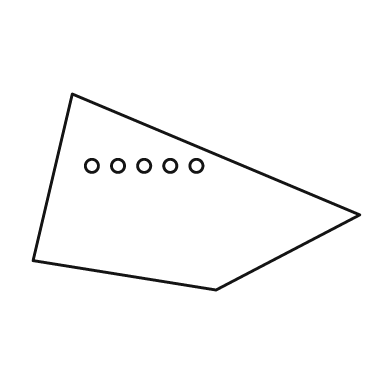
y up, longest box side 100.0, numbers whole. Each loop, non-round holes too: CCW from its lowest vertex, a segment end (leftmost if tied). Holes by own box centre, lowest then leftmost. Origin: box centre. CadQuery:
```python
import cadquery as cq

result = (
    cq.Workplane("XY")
    .moveTo(6.0, -30.0)
    .lineTo(50.0, -7.0)
    .lineTo(-38.0, 30.0)
    .lineTo(-50.0, -21.0)
    .close()
    .moveTo(-32.0, 8.0)
    .circle(2.0)
    .moveTo(-24.0, 8.0)
    .circle(2.0)
    .moveTo(-16.0, 8.0)
    .circle(2.0)
    .moveTo(-8.0, 8.0)
    .circle(2.0)
    .moveTo(0.0, 8.0)
    .circle(2.0)
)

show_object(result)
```